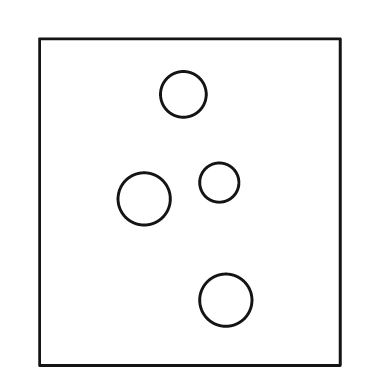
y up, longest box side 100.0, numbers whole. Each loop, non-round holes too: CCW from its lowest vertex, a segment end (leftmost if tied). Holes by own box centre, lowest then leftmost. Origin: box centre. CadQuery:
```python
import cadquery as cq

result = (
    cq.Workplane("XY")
    .moveTo(-46.0, -50.0)
    .lineTo(46.0, -50.0)
    .lineTo(46.0, 50.0)
    .lineTo(-46.0, 50.0)
    .close()
    .moveTo(11.0, -30.0)
    .circle(8.0)
    .moveTo(-14.0, 1.0)
    .circle(8.0)
    .moveTo(9.0, 6.0)
    .circle(6.0)
    .moveTo(-2.0, 33.0)
    .circle(7.0)
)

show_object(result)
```